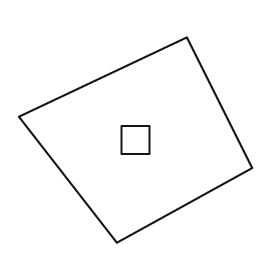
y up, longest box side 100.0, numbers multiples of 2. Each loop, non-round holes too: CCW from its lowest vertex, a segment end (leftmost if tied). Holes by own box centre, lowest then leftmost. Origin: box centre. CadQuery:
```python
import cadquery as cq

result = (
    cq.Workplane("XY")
    .moveTo(-8.0, -44.0)
    .lineTo(50.0, -12.0)
    .lineTo(22.0, 44.0)
    .lineTo(-50.0, 10.0)
    .close()
    .moveTo(-6.0, -6.0)
    .lineTo(6.0, -6.0)
    .lineTo(6.0, 6.0)
    .lineTo(-6.0, 6.0)
    .close()
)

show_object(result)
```